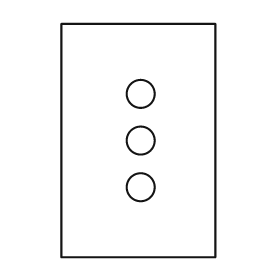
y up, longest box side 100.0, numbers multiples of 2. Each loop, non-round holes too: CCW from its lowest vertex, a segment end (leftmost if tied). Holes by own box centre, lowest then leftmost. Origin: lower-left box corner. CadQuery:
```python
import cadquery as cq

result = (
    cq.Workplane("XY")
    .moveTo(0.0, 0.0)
    .lineTo(66.0, 0.0)
    .lineTo(66.0, 100.0)
    .lineTo(0.0, 100.0)
    .close()
    .moveTo(34.0, 30.0)
    .circle(6.0)
    .moveTo(34.0, 50.0)
    .circle(6.0)
    .moveTo(34.0, 70.0)
    .circle(6.0)
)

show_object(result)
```